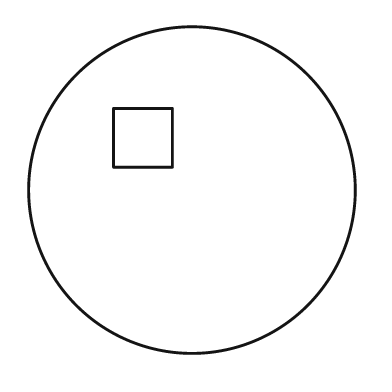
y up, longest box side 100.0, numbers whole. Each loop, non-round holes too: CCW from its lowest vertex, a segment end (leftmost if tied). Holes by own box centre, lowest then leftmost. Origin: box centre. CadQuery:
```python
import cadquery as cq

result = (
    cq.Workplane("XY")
    .moveTo(0.0, 0.0)
    .circle(50.0)
    .moveTo(-24.0, 7.0)
    .lineTo(-6.0, 7.0)
    .lineTo(-6.0, 25.0)
    .lineTo(-24.0, 25.0)
    .close()
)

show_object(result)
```